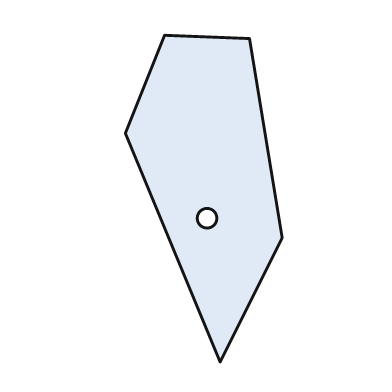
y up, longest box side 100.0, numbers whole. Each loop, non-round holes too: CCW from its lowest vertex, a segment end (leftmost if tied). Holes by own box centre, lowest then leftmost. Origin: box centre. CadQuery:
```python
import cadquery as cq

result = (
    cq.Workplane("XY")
    .moveTo(5.0, -50.0)
    .lineTo(24.0, -12.0)
    .lineTo(14.0, 49.0)
    .lineTo(-12.0, 50.0)
    .lineTo(-24.0, 20.0)
    .close()
    .moveTo(1.0, -6.0)
    .circle(3.0)
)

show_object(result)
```